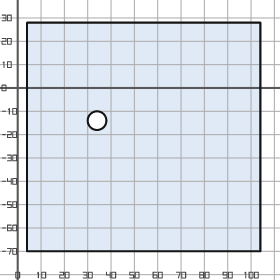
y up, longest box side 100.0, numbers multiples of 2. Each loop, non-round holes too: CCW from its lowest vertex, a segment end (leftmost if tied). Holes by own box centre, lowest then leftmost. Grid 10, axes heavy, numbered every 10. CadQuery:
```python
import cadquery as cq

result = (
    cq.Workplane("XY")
    .moveTo(4.0, -70.0)
    .lineTo(104.0, -70.0)
    .lineTo(104.0, 28.0)
    .lineTo(4.0, 28.0)
    .close()
    .moveTo(34.0, -14.0)
    .circle(4.0)
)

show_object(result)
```